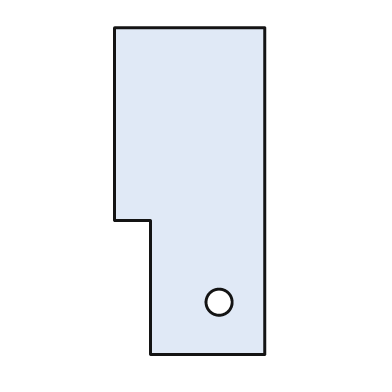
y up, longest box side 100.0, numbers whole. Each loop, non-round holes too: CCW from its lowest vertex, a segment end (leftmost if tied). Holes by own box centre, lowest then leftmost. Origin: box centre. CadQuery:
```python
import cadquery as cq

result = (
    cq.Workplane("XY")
    .moveTo(-12.0, -50.0)
    .lineTo(23.0, -50.0)
    .lineTo(23.0, 50.0)
    .lineTo(-23.0, 50.0)
    .lineTo(-23.0, -9.0)
    .lineTo(-12.0, -9.0)
    .close()
    .moveTo(9.0, -34.0)
    .circle(4.0)
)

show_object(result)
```